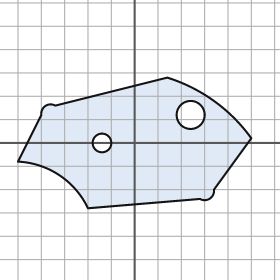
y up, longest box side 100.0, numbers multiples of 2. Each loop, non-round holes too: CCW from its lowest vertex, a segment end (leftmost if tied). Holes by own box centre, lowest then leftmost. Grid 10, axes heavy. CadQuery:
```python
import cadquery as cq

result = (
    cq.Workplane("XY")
    .moveTo(-20.0, -28.0)
    .lineTo(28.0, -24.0)
    .threePointArc((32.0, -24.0), (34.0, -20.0))
    .lineTo(50.0, 2.0)
    .threePointArc((34.0, 18.0), (14.0, 28.0))
    .lineTo(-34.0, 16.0)
    .threePointArc((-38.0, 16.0), (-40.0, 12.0))
    .lineTo(-50.0, -8.0)
    .threePointArc((-32.0, -14.0), (-20.0, -28.0))
    .close()
    .moveTo(-14.0, 0.0)
    .circle(4.0)
    .moveTo(24.0, 12.0)
    .circle(6.0)
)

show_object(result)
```